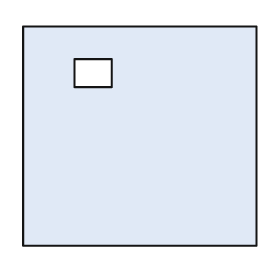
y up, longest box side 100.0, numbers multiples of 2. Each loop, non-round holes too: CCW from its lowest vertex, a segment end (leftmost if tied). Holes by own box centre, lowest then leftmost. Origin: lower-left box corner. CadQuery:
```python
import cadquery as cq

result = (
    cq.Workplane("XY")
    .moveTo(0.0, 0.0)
    .lineTo(100.0, 0.0)
    .lineTo(100.0, 94.0)
    .lineTo(0.0, 94.0)
    .close()
    .moveTo(22.0, 68.0)
    .lineTo(38.0, 68.0)
    .lineTo(38.0, 80.0)
    .lineTo(22.0, 80.0)
    .close()
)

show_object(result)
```